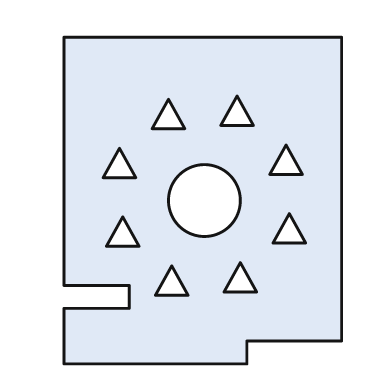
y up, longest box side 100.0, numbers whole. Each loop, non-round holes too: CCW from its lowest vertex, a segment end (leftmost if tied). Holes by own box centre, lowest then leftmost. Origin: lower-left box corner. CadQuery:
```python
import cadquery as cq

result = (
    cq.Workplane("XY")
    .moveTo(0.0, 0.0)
    .lineTo(56.0, 0.0)
    .lineTo(56.0, 7.0)
    .lineTo(85.0, 7.0)
    .lineTo(85.0, 100.0)
    .lineTo(0.0, 100.0)
    .lineTo(0.0, 24.0)
    .lineTo(20.0, 24.0)
    .lineTo(20.0, 17.0)
    .lineTo(0.0, 17.0)
    .close()
    .moveTo(28.0, 21.0)
    .lineTo(38.0, 21.0)
    .lineTo(33.0, 30.0)
    .close()
    .moveTo(49.0, 22.0)
    .lineTo(59.0, 22.0)
    .lineTo(54.0, 31.0)
    .close()
    .moveTo(13.0, 36.0)
    .lineTo(23.0, 36.0)
    .lineTo(18.0, 45.0)
    .close()
    .moveTo(64.0, 37.0)
    .lineTo(74.0, 37.0)
    .lineTo(69.0, 46.0)
    .close()
    .moveTo(43.0, 50.0)
    .circle(11.0)
    .moveTo(12.0, 57.0)
    .lineTo(22.0, 57.0)
    .lineTo(17.0, 66.0)
    .close()
    .moveTo(63.0, 58.0)
    .lineTo(73.0, 58.0)
    .lineTo(68.0, 67.0)
    .close()
    .moveTo(27.0, 72.0)
    .lineTo(37.0, 72.0)
    .lineTo(32.0, 81.0)
    .close()
    .moveTo(48.0, 73.0)
    .lineTo(58.0, 73.0)
    .lineTo(53.0, 82.0)
    .close()
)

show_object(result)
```